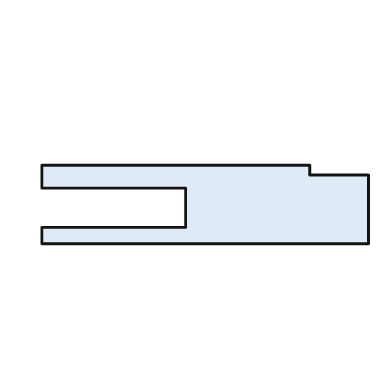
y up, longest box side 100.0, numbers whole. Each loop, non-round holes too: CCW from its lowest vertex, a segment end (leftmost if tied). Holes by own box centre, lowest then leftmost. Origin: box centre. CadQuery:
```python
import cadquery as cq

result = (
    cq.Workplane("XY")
    .moveTo(-50.0, -12.0)
    .lineTo(50.0, -12.0)
    .lineTo(50.0, 9.0)
    .lineTo(32.0, 9.0)
    .lineTo(32.0, 12.0)
    .lineTo(-50.0, 12.0)
    .lineTo(-50.0, 5.0)
    .lineTo(-6.0, 5.0)
    .lineTo(-6.0, -7.0)
    .lineTo(-50.0, -7.0)
    .close()
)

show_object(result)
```